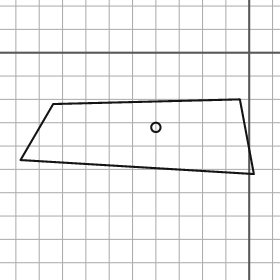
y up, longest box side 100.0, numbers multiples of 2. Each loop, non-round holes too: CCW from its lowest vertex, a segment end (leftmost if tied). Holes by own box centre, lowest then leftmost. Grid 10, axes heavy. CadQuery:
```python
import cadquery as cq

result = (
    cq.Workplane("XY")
    .moveTo(2.0, -52.0)
    .lineTo(-4.0, -20.0)
    .lineTo(-84.0, -22.0)
    .lineTo(-98.0, -46.0)
    .close()
    .moveTo(-40.0, -32.0)
    .circle(2.0)
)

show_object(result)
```